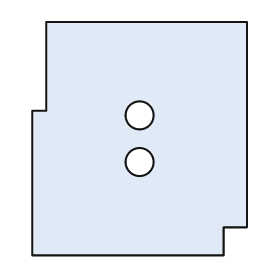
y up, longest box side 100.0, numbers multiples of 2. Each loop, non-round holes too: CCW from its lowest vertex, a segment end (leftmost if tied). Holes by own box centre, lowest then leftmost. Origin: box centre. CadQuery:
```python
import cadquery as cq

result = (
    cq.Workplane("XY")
    .moveTo(-46.0, -50.0)
    .lineTo(36.0, -50.0)
    .lineTo(36.0, -38.0)
    .lineTo(46.0, -38.0)
    .lineTo(46.0, 50.0)
    .lineTo(-40.0, 50.0)
    .lineTo(-40.0, 12.0)
    .lineTo(-46.0, 12.0)
    .close()
    .moveTo(0.0, -10.0)
    .circle(6.0)
    .moveTo(0.0, 10.0)
    .circle(6.0)
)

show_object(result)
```